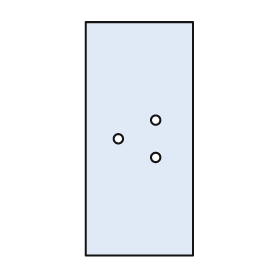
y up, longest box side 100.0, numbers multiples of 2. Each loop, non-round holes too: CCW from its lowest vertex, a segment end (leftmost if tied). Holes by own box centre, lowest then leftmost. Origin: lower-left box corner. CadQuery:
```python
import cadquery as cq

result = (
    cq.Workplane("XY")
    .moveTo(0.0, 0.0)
    .lineTo(46.0, 0.0)
    .lineTo(46.0, 100.0)
    .lineTo(0.0, 100.0)
    .close()
    .moveTo(30.0, 42.0)
    .circle(2.0)
    .moveTo(14.0, 50.0)
    .circle(2.0)
    .moveTo(30.0, 58.0)
    .circle(2.0)
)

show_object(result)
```